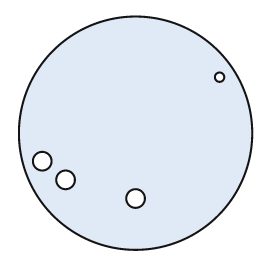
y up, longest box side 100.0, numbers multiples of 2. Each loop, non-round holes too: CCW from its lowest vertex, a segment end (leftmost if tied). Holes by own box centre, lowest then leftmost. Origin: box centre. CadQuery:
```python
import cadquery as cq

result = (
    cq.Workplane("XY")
    .moveTo(0.0, 0.0)
    .circle(50.0)
    .moveTo(0.0, -28.0)
    .circle(4.0)
    .moveTo(-30.0, -20.0)
    .circle(4.0)
    .moveTo(-40.0, -12.0)
    .circle(4.0)
    .moveTo(36.0, 24.0)
    .circle(2.0)
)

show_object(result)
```